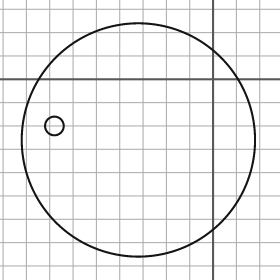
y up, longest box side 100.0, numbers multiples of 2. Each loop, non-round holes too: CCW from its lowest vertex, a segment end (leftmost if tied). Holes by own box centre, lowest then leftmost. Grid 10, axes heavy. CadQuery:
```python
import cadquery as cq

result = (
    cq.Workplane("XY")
    .moveTo(-32.0, -26.0)
    .circle(50.0)
    .moveTo(-68.0, -20.0)
    .circle(4.0)
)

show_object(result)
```